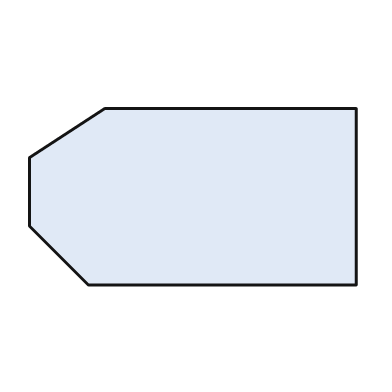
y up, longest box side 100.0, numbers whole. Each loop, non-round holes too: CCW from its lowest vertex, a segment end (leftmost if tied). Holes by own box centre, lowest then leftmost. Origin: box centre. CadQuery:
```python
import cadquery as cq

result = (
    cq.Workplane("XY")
    .moveTo(-32.0, -27.0)
    .lineTo(50.0, -27.0)
    .lineTo(50.0, 27.0)
    .lineTo(-27.0, 27.0)
    .lineTo(-50.0, 12.0)
    .lineTo(-50.0, -9.0)
    .close()
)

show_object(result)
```